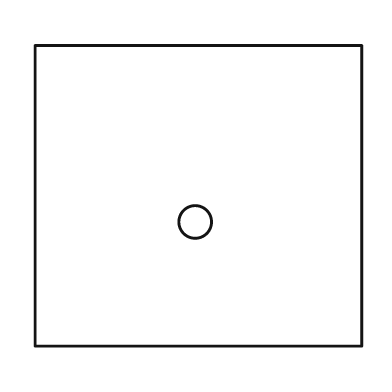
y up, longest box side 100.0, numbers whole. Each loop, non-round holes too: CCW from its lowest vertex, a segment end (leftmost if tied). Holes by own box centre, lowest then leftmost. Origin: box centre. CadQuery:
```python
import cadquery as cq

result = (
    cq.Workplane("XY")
    .moveTo(-50.0, -46.0)
    .lineTo(50.0, -46.0)
    .lineTo(50.0, 46.0)
    .lineTo(-50.0, 46.0)
    .close()
    .moveTo(-1.0, -8.0)
    .circle(5.0)
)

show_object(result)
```